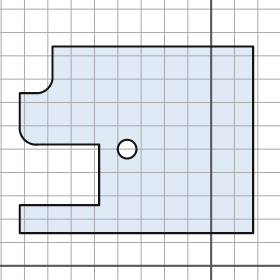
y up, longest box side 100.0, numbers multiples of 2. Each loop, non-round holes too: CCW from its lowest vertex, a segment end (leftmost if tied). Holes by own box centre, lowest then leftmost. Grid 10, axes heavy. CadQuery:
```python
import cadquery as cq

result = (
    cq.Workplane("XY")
    .moveTo(-82.0, 14.0)
    .lineTo(18.0, 14.0)
    .lineTo(18.0, 94.0)
    .lineTo(-68.0, 94.0)
    .lineTo(-68.0, 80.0)
    .threePointArc((-70.0, 76.0), (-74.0, 74.0))
    .lineTo(-82.0, 74.0)
    .lineTo(-82.0, 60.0)
    .threePointArc((-80.0, 54.0), (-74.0, 52.0))
    .lineTo(-48.0, 52.0)
    .lineTo(-48.0, 26.0)
    .lineTo(-82.0, 26.0)
    .close()
    .moveTo(-36.0, 50.0)
    .circle(4.0)
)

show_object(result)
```